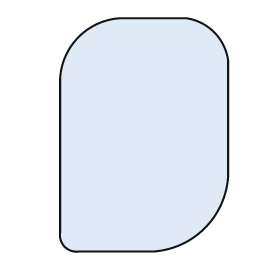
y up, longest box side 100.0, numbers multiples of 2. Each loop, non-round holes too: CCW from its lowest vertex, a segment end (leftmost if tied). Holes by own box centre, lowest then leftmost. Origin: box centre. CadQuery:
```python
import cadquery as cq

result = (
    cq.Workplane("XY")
    .moveTo(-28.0, -50.0)
    .lineTo(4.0, -50.0)
    .threePointArc((26.0, -40.0), (36.0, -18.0))
    .lineTo(36.0, 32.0)
    .threePointArc((30.0, 44.0), (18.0, 50.0))
    .lineTo(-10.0, 50.0)
    .threePointArc((-28.0, 42.0), (-36.0, 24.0))
    .lineTo(-36.0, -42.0)
    .threePointArc((-34.0, -48.0), (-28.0, -50.0))
    .close()
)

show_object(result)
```